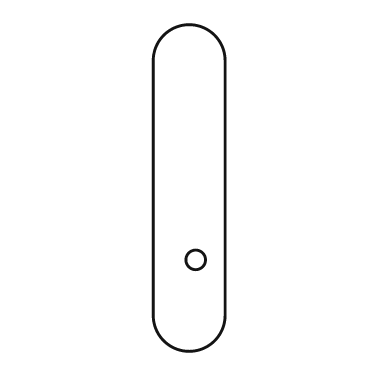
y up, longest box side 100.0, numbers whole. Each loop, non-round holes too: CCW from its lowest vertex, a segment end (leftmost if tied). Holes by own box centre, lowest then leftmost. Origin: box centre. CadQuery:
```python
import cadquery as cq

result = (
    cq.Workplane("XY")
    .moveTo(-11.0, -39.0)
    .threePointArc((0.0, -50.0), (11.0, -39.0))
    .lineTo(11.0, 39.0)
    .threePointArc((0.0, 50.0), (-11.0, 39.0))
    .close()
    .moveTo(2.0, -22.0)
    .circle(3.0)
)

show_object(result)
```